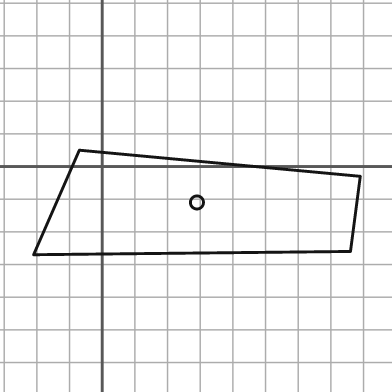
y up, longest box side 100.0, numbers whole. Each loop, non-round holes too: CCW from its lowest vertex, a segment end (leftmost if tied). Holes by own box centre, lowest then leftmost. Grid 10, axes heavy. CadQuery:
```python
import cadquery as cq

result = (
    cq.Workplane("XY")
    .moveTo(-21.0, -27.0)
    .lineTo(76.0, -26.0)
    .lineTo(79.0, -3.0)
    .lineTo(-7.0, 5.0)
    .close()
    .moveTo(29.0, -11.0)
    .circle(2.0)
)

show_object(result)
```